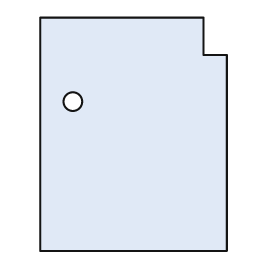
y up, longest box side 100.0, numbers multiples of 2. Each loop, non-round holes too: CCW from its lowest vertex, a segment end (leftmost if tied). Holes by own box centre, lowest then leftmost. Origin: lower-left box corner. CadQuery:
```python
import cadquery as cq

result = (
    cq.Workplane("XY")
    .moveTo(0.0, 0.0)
    .lineTo(80.0, 0.0)
    .lineTo(80.0, 84.0)
    .lineTo(70.0, 84.0)
    .lineTo(70.0, 100.0)
    .lineTo(0.0, 100.0)
    .close()
    .moveTo(14.0, 64.0)
    .circle(4.0)
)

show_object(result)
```